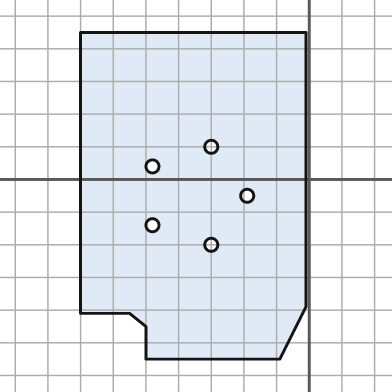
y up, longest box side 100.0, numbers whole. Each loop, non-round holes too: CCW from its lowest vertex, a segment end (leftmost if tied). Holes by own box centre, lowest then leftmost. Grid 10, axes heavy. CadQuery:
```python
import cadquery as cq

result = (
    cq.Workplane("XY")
    .moveTo(-50.0, -55.0)
    .lineTo(-9.0, -55.0)
    .lineTo(-1.0, -39.0)
    .lineTo(-1.0, 45.0)
    .lineTo(-70.0, 45.0)
    .lineTo(-70.0, -41.0)
    .lineTo(-55.0, -41.0)
    .lineTo(-50.0, -45.0)
    .close()
    .moveTo(-30.0, -20.0)
    .circle(2.0)
    .moveTo(-48.0, -14.0)
    .circle(2.0)
    .moveTo(-19.0, -5.0)
    .circle(2.0)
    .moveTo(-48.0, 4.0)
    .circle(2.0)
    .moveTo(-30.0, 10.0)
    .circle(2.0)
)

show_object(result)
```